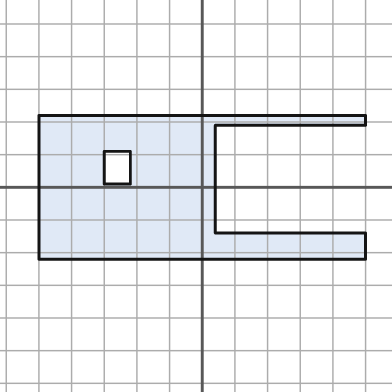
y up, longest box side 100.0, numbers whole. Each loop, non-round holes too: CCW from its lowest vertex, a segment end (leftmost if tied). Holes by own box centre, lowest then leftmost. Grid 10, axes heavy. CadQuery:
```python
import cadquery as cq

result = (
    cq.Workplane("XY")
    .moveTo(-50.0, -22.0)
    .lineTo(50.0, -22.0)
    .lineTo(50.0, -14.0)
    .lineTo(4.0, -14.0)
    .lineTo(4.0, 19.0)
    .lineTo(50.0, 19.0)
    .lineTo(50.0, 22.0)
    .lineTo(-50.0, 22.0)
    .close()
    .moveTo(-30.0, 1.0)
    .lineTo(-22.0, 1.0)
    .lineTo(-22.0, 11.0)
    .lineTo(-30.0, 11.0)
    .close()
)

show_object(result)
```